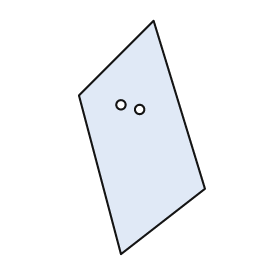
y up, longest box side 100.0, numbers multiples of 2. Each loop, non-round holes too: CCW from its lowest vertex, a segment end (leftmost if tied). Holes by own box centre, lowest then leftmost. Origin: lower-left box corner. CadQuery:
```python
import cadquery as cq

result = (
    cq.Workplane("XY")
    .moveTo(18.0, 0.0)
    .lineTo(54.0, 28.0)
    .lineTo(32.0, 100.0)
    .lineTo(0.0, 68.0)
    .close()
    .moveTo(26.0, 62.0)
    .circle(2.0)
    .moveTo(18.0, 64.0)
    .circle(2.0)
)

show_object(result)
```